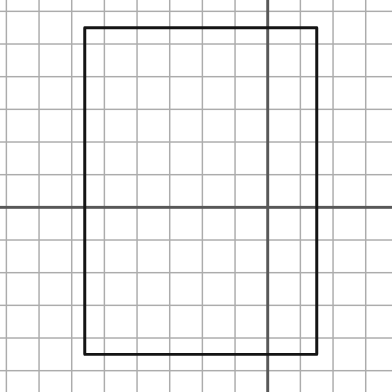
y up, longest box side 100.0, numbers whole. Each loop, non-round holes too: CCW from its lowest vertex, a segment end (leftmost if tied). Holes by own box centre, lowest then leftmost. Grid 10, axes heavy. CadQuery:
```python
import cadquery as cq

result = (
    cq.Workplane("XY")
    .moveTo(-56.0, -45.0)
    .lineTo(15.0, -45.0)
    .lineTo(15.0, 55.0)
    .lineTo(-56.0, 55.0)
    .close()
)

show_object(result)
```